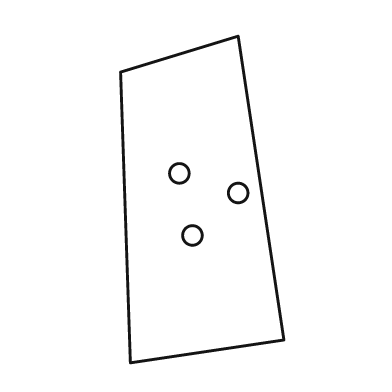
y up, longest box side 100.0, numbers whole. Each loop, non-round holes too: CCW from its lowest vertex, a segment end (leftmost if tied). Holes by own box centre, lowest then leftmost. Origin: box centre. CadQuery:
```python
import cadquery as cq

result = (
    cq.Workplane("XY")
    .moveTo(-22.0, -50.0)
    .lineTo(25.0, -43.0)
    .lineTo(11.0, 50.0)
    .lineTo(-25.0, 39.0)
    .close()
    .moveTo(-3.0, -11.0)
    .circle(3.0)
    .moveTo(11.0, 2.0)
    .circle(3.0)
    .moveTo(-7.0, 8.0)
    .circle(3.0)
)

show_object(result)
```